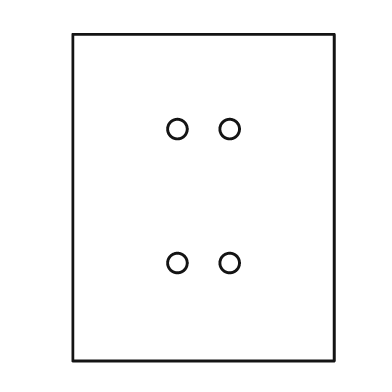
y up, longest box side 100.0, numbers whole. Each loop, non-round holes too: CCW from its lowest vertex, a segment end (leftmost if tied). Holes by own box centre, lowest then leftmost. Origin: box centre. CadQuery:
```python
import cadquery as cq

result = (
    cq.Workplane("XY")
    .moveTo(-40.0, -50.0)
    .lineTo(40.0, -50.0)
    .lineTo(40.0, 50.0)
    .lineTo(-40.0, 50.0)
    .close()
    .moveTo(-8.0, -20.0)
    .circle(3.0)
    .moveTo(8.0, -20.0)
    .circle(3.0)
    .moveTo(-8.0, 21.0)
    .circle(3.0)
    .moveTo(8.0, 21.0)
    .circle(3.0)
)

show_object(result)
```